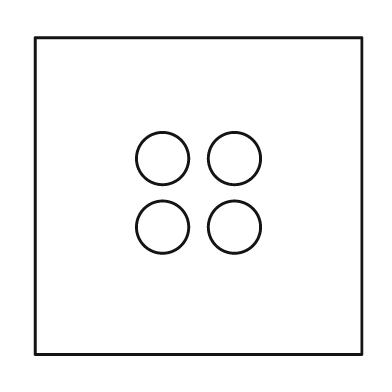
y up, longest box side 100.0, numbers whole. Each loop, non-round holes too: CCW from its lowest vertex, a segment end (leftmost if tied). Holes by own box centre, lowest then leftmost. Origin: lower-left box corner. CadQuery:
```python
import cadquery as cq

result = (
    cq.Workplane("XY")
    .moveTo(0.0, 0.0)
    .lineTo(100.0, 0.0)
    .lineTo(100.0, 97.0)
    .lineTo(0.0, 97.0)
    .close()
    .moveTo(39.0, 39.0)
    .circle(8.0)
    .moveTo(61.0, 39.0)
    .circle(8.0)
    .moveTo(39.0, 60.0)
    .circle(8.0)
    .moveTo(61.0, 60.0)
    .circle(8.0)
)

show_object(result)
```